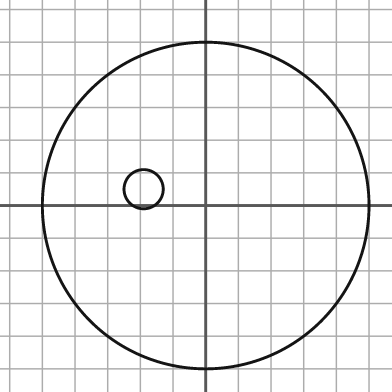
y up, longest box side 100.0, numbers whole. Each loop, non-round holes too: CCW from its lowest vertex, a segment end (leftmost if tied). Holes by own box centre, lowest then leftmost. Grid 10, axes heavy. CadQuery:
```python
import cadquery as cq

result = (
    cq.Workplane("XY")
    .moveTo(0.0, 0.0)
    .circle(50.0)
    .moveTo(-19.0, 5.0)
    .circle(6.0)
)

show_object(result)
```